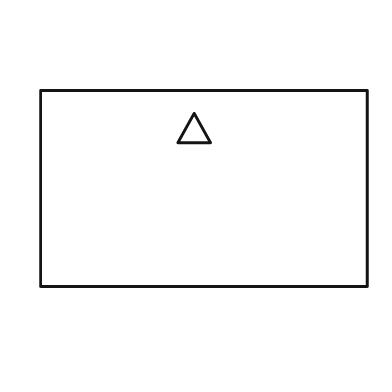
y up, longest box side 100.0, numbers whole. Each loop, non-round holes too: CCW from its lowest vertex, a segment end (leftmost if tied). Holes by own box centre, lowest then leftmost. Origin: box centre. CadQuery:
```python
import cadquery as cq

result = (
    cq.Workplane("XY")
    .moveTo(-50.0, -30.0)
    .lineTo(50.0, -30.0)
    .lineTo(50.0, 30.0)
    .lineTo(-50.0, 30.0)
    .close()
    .moveTo(-8.0, 14.0)
    .lineTo(2.0, 14.0)
    .lineTo(-3.0, 23.0)
    .close()
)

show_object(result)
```